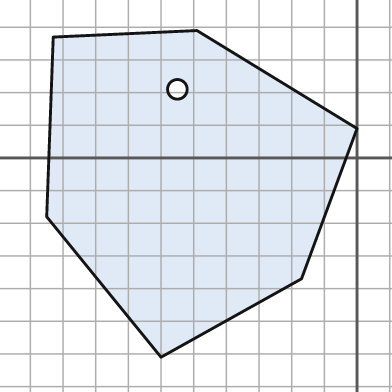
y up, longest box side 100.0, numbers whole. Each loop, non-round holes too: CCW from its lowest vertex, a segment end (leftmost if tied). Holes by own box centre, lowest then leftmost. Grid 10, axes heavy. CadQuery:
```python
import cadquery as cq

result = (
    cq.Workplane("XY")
    .moveTo(-60.0, -61.0)
    .lineTo(-17.0, -37.0)
    .lineTo(0.0, 9.0)
    .lineTo(-49.0, 39.0)
    .lineTo(-93.0, 37.0)
    .lineTo(-95.0, -18.0)
    .close()
    .moveTo(-55.0, 21.0)
    .circle(3.0)
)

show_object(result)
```